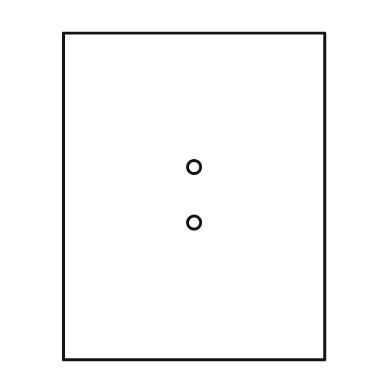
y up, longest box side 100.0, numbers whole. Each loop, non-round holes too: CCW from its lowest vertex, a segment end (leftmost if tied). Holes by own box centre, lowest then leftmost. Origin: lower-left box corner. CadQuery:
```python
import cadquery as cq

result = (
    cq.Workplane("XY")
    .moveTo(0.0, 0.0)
    .lineTo(80.0, 0.0)
    .lineTo(80.0, 100.0)
    .lineTo(0.0, 100.0)
    .close()
    .moveTo(40.0, 42.0)
    .circle(2.0)
    .moveTo(40.0, 59.0)
    .circle(2.0)
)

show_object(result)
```